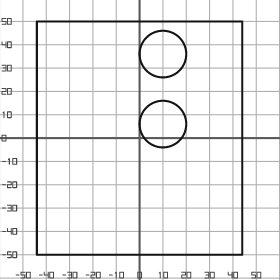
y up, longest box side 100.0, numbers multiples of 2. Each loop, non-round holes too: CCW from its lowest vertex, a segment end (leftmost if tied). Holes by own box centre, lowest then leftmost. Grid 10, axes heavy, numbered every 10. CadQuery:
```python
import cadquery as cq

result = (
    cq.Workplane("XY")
    .moveTo(-44.0, -50.0)
    .lineTo(44.0, -50.0)
    .lineTo(44.0, 50.0)
    .lineTo(-44.0, 50.0)
    .close()
    .moveTo(10.0, 6.0)
    .circle(10.0)
    .moveTo(10.0, 36.0)
    .circle(10.0)
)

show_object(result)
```